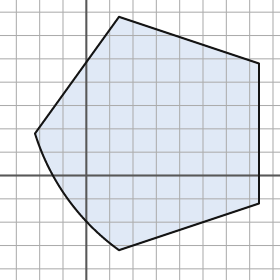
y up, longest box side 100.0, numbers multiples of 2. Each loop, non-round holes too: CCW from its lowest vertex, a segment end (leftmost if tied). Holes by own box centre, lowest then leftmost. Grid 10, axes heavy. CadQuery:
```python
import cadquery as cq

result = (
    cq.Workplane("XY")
    .moveTo(14.0, -32.0)
    .lineTo(74.0, -12.0)
    .lineTo(74.0, 48.0)
    .lineTo(14.0, 68.0)
    .lineTo(-22.0, 18.0)
    .threePointArc((-8.0, -10.0), (14.0, -32.0))
    .close()
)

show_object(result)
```